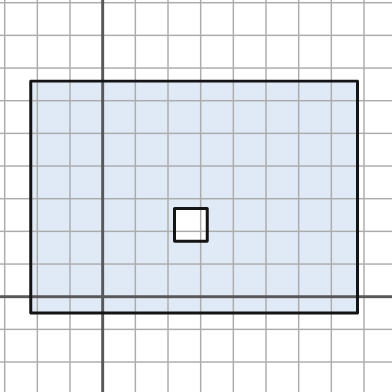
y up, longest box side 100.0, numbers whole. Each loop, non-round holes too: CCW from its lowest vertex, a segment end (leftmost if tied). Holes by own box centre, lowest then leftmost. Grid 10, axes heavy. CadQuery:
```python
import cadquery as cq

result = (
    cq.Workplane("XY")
    .moveTo(-22.0, -5.0)
    .lineTo(78.0, -5.0)
    .lineTo(78.0, 66.0)
    .lineTo(-22.0, 66.0)
    .close()
    .moveTo(22.0, 17.0)
    .lineTo(32.0, 17.0)
    .lineTo(32.0, 27.0)
    .lineTo(22.0, 27.0)
    .close()
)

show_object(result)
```